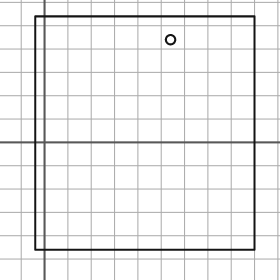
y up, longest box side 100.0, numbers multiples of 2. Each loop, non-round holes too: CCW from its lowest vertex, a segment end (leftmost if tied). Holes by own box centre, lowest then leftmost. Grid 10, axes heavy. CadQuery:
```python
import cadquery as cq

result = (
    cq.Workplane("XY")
    .moveTo(-4.0, -46.0)
    .lineTo(90.0, -46.0)
    .lineTo(90.0, 54.0)
    .lineTo(-4.0, 54.0)
    .close()
    .moveTo(54.0, 44.0)
    .circle(2.0)
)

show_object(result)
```